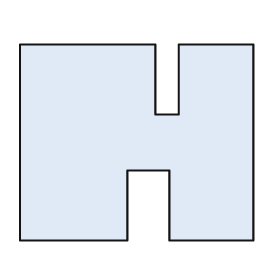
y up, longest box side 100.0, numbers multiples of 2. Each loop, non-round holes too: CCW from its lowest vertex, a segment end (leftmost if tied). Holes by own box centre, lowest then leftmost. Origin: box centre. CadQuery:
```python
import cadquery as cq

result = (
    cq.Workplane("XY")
    .moveTo(-50.0, -42.0)
    .lineTo(-4.0, -42.0)
    .lineTo(-4.0, -12.0)
    .lineTo(14.0, -12.0)
    .lineTo(14.0, -42.0)
    .lineTo(50.0, -42.0)
    .lineTo(50.0, 42.0)
    .lineTo(18.0, 42.0)
    .lineTo(18.0, 12.0)
    .lineTo(8.0, 12.0)
    .lineTo(8.0, 42.0)
    .lineTo(-50.0, 42.0)
    .close()
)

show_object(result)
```